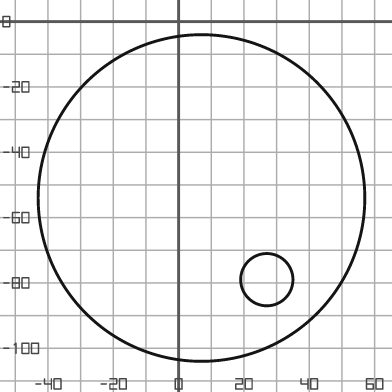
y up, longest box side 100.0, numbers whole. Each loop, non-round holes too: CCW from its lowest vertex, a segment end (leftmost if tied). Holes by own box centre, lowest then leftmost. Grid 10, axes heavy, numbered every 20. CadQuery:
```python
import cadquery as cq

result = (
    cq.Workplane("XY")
    .moveTo(7.0, -54.0)
    .circle(50.0)
    .moveTo(27.0, -79.0)
    .circle(8.0)
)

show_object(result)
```